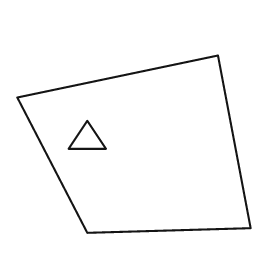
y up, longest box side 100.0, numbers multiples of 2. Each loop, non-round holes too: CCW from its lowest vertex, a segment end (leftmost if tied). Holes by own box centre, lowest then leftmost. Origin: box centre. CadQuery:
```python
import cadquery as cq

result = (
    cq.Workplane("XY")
    .moveTo(-20.0, -38.0)
    .lineTo(50.0, -36.0)
    .lineTo(36.0, 38.0)
    .lineTo(-50.0, 20.0)
    .close()
    .moveTo(-28.0, -2.0)
    .lineTo(-12.0, -2.0)
    .lineTo(-20.0, 10.0)
    .close()
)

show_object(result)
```